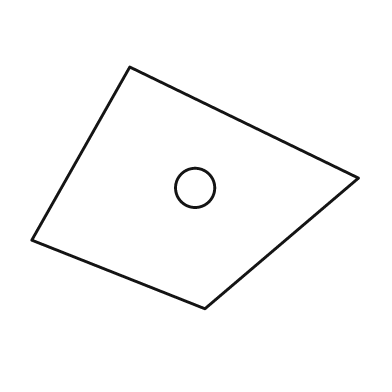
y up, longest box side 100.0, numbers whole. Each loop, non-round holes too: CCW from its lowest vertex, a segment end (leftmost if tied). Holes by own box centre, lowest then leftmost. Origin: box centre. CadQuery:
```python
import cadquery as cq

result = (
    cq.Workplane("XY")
    .moveTo(3.0, -37.0)
    .lineTo(50.0, 3.0)
    .lineTo(-20.0, 37.0)
    .lineTo(-50.0, -16.0)
    .close()
    .moveTo(0.0, 0.0)
    .circle(6.0)
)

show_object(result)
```